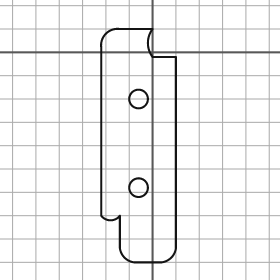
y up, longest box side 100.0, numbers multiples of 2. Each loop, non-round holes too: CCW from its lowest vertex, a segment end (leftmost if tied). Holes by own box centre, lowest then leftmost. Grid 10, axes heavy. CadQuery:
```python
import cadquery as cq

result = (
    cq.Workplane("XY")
    .moveTo(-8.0, -90.0)
    .lineTo(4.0, -90.0)
    .threePointArc((8.0, -88.0), (10.0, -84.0))
    .lineTo(10.0, -2.0)
    .lineTo(0.0, -2.0)
    .threePointArc((-2.0, 4.0), (0.0, 10.0))
    .lineTo(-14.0, 10.0)
    .threePointArc((-20.0, 8.0), (-22.0, 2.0))
    .lineTo(-22.0, -70.0)
    .threePointArc((-18.0, -72.0), (-14.0, -70.0))
    .lineTo(-14.0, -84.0)
    .threePointArc((-12.0, -88.0), (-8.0, -90.0))
    .close()
    .moveTo(-6.0, -58.0)
    .circle(4.0)
    .moveTo(-6.0, -20.0)
    .circle(4.0)
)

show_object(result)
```